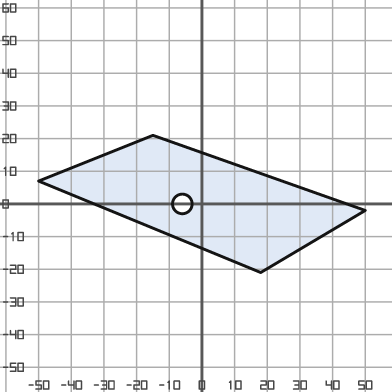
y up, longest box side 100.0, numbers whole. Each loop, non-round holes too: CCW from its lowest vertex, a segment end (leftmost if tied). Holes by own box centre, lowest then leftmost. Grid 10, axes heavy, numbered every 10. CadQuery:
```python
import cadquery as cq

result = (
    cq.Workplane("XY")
    .moveTo(18.0, -21.0)
    .lineTo(50.0, -2.0)
    .lineTo(-15.0, 21.0)
    .lineTo(-50.0, 7.0)
    .close()
    .moveTo(-6.0, 0.0)
    .circle(3.0)
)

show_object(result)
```